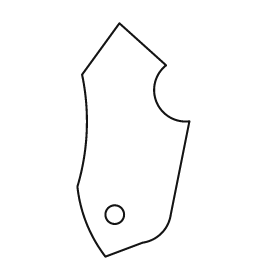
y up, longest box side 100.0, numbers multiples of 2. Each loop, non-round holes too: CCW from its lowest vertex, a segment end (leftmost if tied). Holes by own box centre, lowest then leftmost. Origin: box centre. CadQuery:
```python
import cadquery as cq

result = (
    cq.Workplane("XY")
    .moveTo(-12.0, -50.0)
    .lineTo(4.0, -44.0)
    .threePointArc((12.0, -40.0), (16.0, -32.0))
    .lineTo(24.0, 8.0)
    .threePointArc((10.0, 16.0), (14.0, 32.0))
    .lineTo(-6.0, 50.0)
    .lineTo(-22.0, 28.0)
    .threePointArc((-20.0, 4.0), (-24.0, -20.0))
    .threePointArc((-20.0, -36.0), (-12.0, -50.0))
    .close()
    .moveTo(-8.0, -32.0)
    .circle(4.0)
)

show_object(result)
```